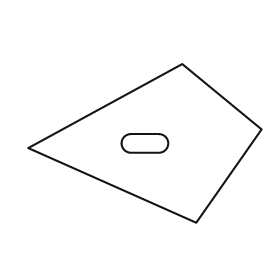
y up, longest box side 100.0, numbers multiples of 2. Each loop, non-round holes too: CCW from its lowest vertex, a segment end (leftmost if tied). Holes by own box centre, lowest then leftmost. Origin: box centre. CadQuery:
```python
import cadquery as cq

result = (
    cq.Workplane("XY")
    .moveTo(22.0, -34.0)
    .lineTo(50.0, 6.0)
    .lineTo(16.0, 34.0)
    .lineTo(-50.0, -2.0)
    .close()
    .moveTo(-6.0, -4.0)
    .lineTo(6.0, -4.0)
    .threePointArc((10.0, 0.0), (6.0, 4.0))
    .lineTo(-6.0, 4.0)
    .threePointArc((-10.0, 0.0), (-6.0, -4.0))
    .close()
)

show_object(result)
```